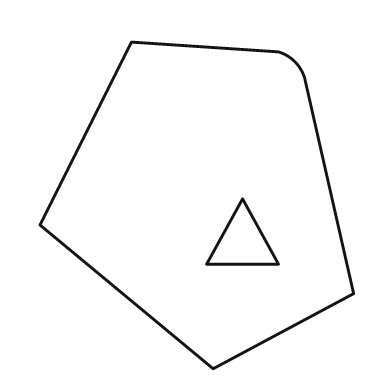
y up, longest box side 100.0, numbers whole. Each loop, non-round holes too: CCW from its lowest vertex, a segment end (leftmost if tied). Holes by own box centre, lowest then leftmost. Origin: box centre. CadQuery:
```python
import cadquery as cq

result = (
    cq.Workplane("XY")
    .moveTo(5.0, -50.0)
    .lineTo(48.0, -27.0)
    .lineTo(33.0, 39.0)
    .threePointArc((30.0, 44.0), (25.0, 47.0))
    .lineTo(-20.0, 50.0)
    .lineTo(-48.0, -6.0)
    .close()
    .moveTo(3.0, -18.0)
    .lineTo(25.0, -18.0)
    .lineTo(14.0, 2.0)
    .close()
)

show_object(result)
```